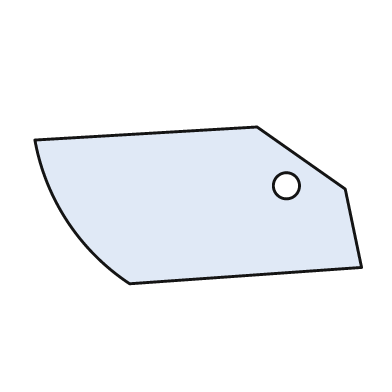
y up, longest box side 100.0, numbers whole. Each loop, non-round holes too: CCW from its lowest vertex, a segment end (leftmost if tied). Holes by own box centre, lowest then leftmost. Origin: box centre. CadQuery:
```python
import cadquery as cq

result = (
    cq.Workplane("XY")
    .moveTo(-21.0, -24.0)
    .lineTo(50.0, -19.0)
    .lineTo(45.0, 5.0)
    .lineTo(18.0, 24.0)
    .lineTo(-50.0, 20.0)
    .threePointArc((-40.0, -5.0), (-21.0, -24.0))
    .close()
    .moveTo(27.0, 6.0)
    .circle(4.0)
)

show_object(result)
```